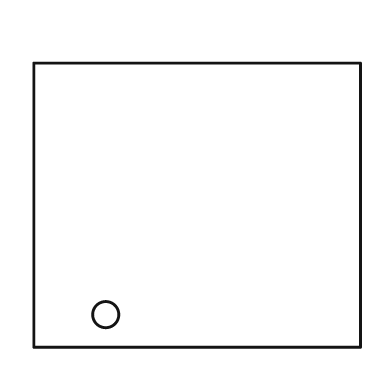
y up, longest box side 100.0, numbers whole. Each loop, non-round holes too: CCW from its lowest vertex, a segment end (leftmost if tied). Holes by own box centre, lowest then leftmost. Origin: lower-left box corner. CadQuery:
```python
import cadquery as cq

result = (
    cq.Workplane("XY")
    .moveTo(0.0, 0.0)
    .lineTo(100.0, 0.0)
    .lineTo(100.0, 87.0)
    .lineTo(0.0, 87.0)
    .close()
    .moveTo(22.0, 10.0)
    .circle(4.0)
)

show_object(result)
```